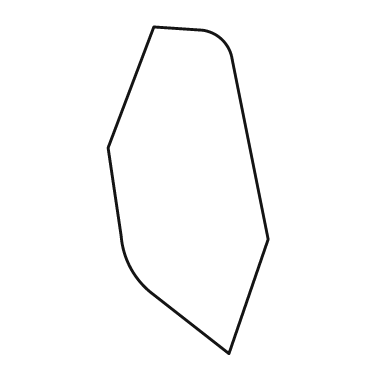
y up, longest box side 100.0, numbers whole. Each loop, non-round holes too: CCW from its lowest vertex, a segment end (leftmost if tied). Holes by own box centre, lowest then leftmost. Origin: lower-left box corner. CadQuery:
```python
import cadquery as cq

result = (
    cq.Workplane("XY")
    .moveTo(37.0, 0.0)
    .lineTo(49.0, 35.0)
    .lineTo(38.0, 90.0)
    .threePointArc((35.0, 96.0), (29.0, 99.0))
    .lineTo(14.0, 100.0)
    .lineTo(0.0, 63.0)
    .lineTo(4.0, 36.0)
    .threePointArc((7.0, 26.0), (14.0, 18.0))
    .close()
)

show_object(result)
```